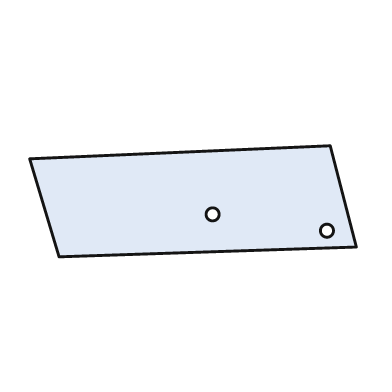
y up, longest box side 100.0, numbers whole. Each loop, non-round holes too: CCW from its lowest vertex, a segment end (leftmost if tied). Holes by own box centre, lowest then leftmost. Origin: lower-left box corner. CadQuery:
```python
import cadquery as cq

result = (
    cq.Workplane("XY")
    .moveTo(9.0, 0.0)
    .lineTo(100.0, 3.0)
    .lineTo(92.0, 34.0)
    .lineTo(0.0, 30.0)
    .close()
    .moveTo(91.0, 8.0)
    .circle(2.0)
    .moveTo(56.0, 13.0)
    .circle(2.0)
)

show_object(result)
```